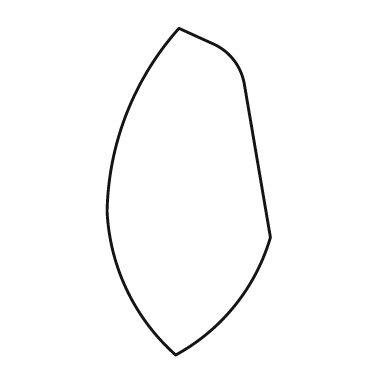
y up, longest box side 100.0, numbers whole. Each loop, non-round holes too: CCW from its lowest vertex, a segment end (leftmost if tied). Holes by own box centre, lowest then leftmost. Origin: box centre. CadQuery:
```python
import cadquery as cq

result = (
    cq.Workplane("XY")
    .moveTo(-4.0, -50.0)
    .threePointArc((14.0, -35.0), (25.0, -14.0))
    .lineTo(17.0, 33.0)
    .threePointArc((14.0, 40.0), (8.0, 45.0))
    .lineTo(-3.0, 50.0)
    .threePointArc((-19.0, 24.0), (-25.0, -6.0))
    .threePointArc((-19.0, -30.0), (-4.0, -50.0))
    .close()
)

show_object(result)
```